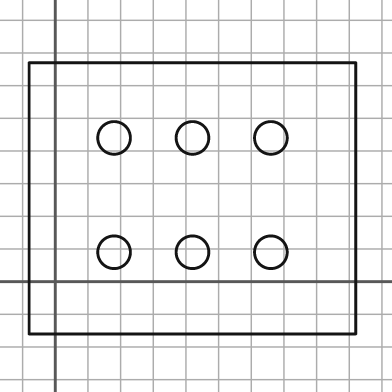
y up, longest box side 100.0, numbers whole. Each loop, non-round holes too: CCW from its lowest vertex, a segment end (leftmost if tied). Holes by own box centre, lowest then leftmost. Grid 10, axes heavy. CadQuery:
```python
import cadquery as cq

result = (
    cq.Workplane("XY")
    .moveTo(-8.0, -16.0)
    .lineTo(92.0, -16.0)
    .lineTo(92.0, 67.0)
    .lineTo(-8.0, 67.0)
    .close()
    .moveTo(18.0, 9.0)
    .circle(5.0)
    .moveTo(42.0, 9.0)
    .circle(5.0)
    .moveTo(66.0, 9.0)
    .circle(5.0)
    .moveTo(18.0, 44.0)
    .circle(5.0)
    .moveTo(42.0, 44.0)
    .circle(5.0)
    .moveTo(66.0, 44.0)
    .circle(5.0)
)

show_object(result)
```